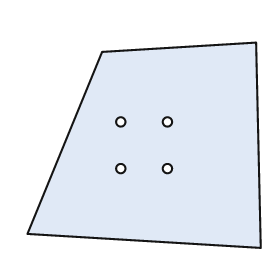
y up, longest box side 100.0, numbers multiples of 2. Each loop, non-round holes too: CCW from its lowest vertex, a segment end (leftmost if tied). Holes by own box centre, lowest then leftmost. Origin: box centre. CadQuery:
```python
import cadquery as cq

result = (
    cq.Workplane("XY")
    .moveTo(50.0, -44.0)
    .lineTo(48.0, 44.0)
    .lineTo(-18.0, 40.0)
    .lineTo(-50.0, -38.0)
    .close()
    .moveTo(-10.0, -10.0)
    .circle(2.0)
    .moveTo(10.0, -10.0)
    .circle(2.0)
    .moveTo(-10.0, 10.0)
    .circle(2.0)
    .moveTo(10.0, 10.0)
    .circle(2.0)
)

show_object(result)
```